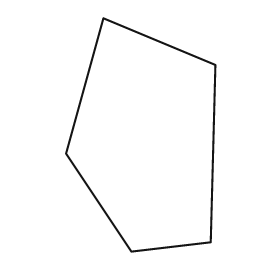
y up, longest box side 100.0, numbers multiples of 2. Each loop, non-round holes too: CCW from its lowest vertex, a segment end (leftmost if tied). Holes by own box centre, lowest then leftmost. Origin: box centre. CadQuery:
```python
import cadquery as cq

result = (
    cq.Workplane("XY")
    .moveTo(-4.0, -50.0)
    .lineTo(30.0, -46.0)
    .lineTo(32.0, 30.0)
    .lineTo(-16.0, 50.0)
    .lineTo(-32.0, -8.0)
    .close()
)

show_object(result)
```